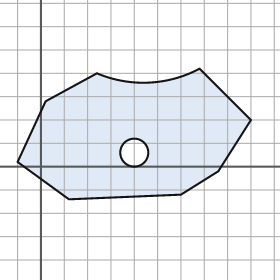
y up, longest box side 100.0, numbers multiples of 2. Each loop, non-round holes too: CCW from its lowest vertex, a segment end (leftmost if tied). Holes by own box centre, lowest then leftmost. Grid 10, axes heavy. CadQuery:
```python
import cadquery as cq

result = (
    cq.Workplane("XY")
    .moveTo(12.0, -14.0)
    .lineTo(60.0, -12.0)
    .lineTo(76.0, -2.0)
    .lineTo(90.0, 20.0)
    .lineTo(68.0, 42.0)
    .threePointArc((46.0, 36.0), (24.0, 40.0))
    .lineTo(2.0, 28.0)
    .lineTo(-10.0, 2.0)
    .close()
    .moveTo(40.0, 6.0)
    .circle(6.0)
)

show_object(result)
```